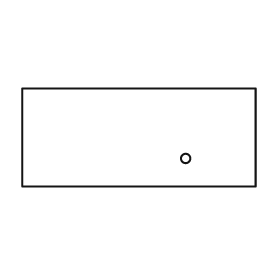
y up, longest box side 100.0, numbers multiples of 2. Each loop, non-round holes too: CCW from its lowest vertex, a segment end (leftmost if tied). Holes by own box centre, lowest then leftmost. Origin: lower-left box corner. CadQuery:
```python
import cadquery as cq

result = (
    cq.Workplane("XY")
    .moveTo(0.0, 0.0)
    .lineTo(100.0, 0.0)
    .lineTo(100.0, 42.0)
    .lineTo(0.0, 42.0)
    .close()
    .moveTo(70.0, 12.0)
    .circle(2.0)
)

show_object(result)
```